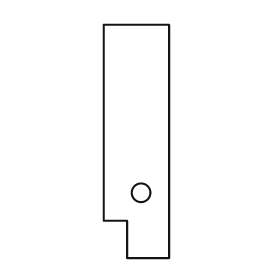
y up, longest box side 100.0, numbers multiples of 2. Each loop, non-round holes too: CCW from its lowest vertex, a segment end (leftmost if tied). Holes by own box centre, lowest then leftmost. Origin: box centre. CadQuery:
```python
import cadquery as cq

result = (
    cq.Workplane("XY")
    .moveTo(-4.0, -50.0)
    .lineTo(14.0, -50.0)
    .lineTo(14.0, 50.0)
    .lineTo(-14.0, 50.0)
    .lineTo(-14.0, -34.0)
    .lineTo(-4.0, -34.0)
    .close()
    .moveTo(2.0, -22.0)
    .circle(4.0)
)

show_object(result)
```